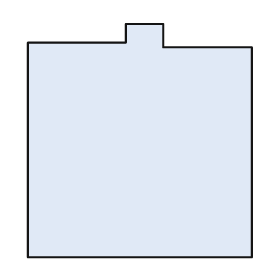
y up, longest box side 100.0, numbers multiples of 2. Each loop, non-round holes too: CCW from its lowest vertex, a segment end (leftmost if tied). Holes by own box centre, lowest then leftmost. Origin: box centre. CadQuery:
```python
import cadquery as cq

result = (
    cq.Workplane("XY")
    .moveTo(-48.0, -50.0)
    .lineTo(48.0, -50.0)
    .lineTo(48.0, 40.0)
    .lineTo(10.0, 40.0)
    .lineTo(10.0, 50.0)
    .lineTo(-6.0, 50.0)
    .lineTo(-6.0, 42.0)
    .lineTo(-48.0, 42.0)
    .close()
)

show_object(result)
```